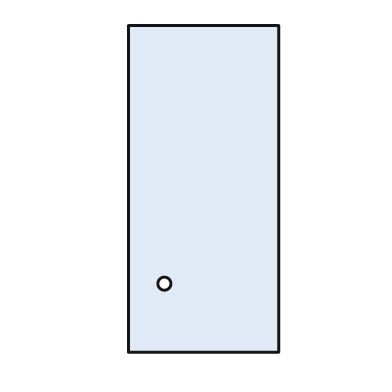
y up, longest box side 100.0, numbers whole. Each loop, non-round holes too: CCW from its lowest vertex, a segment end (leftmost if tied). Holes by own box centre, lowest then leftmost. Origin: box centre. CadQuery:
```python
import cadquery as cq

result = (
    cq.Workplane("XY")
    .moveTo(-23.0, -50.0)
    .lineTo(23.0, -50.0)
    .lineTo(23.0, 50.0)
    .lineTo(-23.0, 50.0)
    .close()
    .moveTo(-12.0, -29.0)
    .circle(2.0)
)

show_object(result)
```